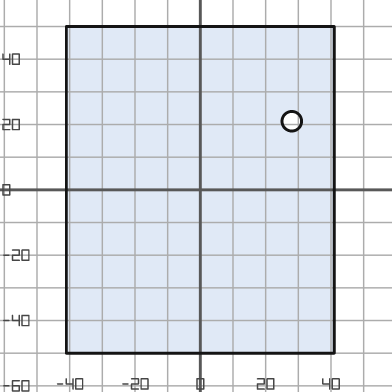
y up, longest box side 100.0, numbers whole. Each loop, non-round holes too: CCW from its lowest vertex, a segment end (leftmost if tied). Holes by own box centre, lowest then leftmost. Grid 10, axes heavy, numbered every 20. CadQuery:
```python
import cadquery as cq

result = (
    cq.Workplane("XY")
    .moveTo(-41.0, -50.0)
    .lineTo(41.0, -50.0)
    .lineTo(41.0, 50.0)
    .lineTo(-41.0, 50.0)
    .close()
    .moveTo(28.0, 21.0)
    .circle(3.0)
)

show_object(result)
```